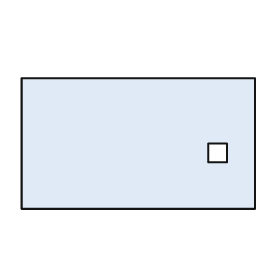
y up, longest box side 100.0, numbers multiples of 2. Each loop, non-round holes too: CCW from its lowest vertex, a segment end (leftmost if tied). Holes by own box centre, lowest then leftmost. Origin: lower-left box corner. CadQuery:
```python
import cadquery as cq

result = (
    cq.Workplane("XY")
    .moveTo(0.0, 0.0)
    .lineTo(100.0, 0.0)
    .lineTo(100.0, 56.0)
    .lineTo(0.0, 56.0)
    .close()
    .moveTo(80.0, 20.0)
    .lineTo(88.0, 20.0)
    .lineTo(88.0, 28.0)
    .lineTo(80.0, 28.0)
    .close()
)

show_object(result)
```